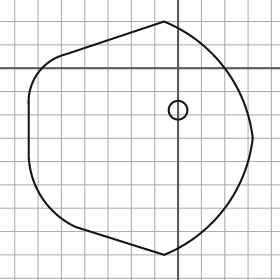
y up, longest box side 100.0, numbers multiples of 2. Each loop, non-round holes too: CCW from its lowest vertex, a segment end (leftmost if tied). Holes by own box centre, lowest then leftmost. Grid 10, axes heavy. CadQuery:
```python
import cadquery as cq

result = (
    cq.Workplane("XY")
    .moveTo(-6.0, -80.0)
    .threePointArc((20.0, -60.0), (32.0, -30.0))
    .threePointArc((20.0, 0.0), (-6.0, 20.0))
    .lineTo(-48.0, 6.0)
    .threePointArc((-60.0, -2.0), (-64.0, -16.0))
    .lineTo(-64.0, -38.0)
    .threePointArc((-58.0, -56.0), (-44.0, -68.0))
    .close()
    .moveTo(0.0, -18.0)
    .circle(4.0)
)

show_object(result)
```